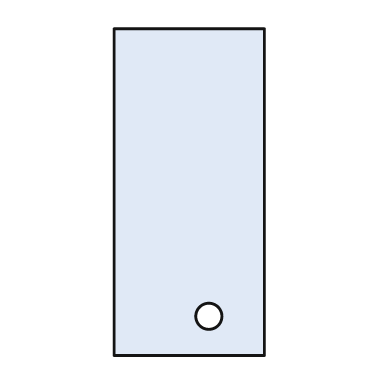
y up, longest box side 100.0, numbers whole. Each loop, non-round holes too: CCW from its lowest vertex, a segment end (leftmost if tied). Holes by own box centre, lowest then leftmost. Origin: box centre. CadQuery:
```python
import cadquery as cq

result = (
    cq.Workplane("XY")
    .moveTo(-23.0, -50.0)
    .lineTo(23.0, -50.0)
    .lineTo(23.0, 50.0)
    .lineTo(-23.0, 50.0)
    .close()
    .moveTo(6.0, -38.0)
    .circle(4.0)
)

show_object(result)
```